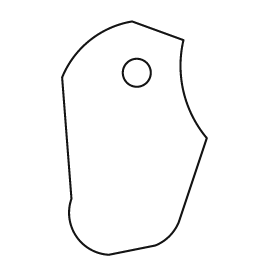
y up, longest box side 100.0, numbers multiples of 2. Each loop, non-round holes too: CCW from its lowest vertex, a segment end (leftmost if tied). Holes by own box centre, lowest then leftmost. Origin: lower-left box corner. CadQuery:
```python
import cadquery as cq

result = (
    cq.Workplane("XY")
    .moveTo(20.0, 0.0)
    .lineTo(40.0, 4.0)
    .threePointArc((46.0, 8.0), (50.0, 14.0))
    .lineTo(62.0, 50.0)
    .threePointArc((52.0, 70.0), (52.0, 92.0))
    .lineTo(30.0, 100.0)
    .threePointArc((12.0, 92.0), (0.0, 76.0))
    .lineTo(4.0, 24.0)
    .threePointArc((6.0, 8.0), (20.0, 0.0))
    .close()
    .moveTo(32.0, 78.0)
    .circle(6.0)
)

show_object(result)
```